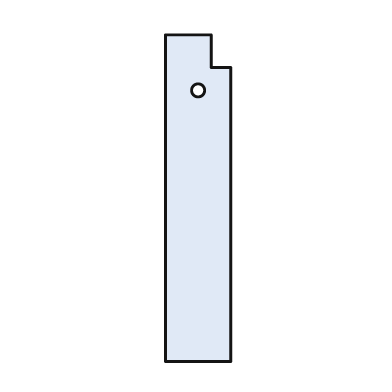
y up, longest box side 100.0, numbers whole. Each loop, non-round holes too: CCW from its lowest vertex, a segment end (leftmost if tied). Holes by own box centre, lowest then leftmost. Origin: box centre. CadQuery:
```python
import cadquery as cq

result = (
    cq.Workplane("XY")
    .moveTo(-10.0, -50.0)
    .lineTo(10.0, -50.0)
    .lineTo(10.0, 40.0)
    .lineTo(4.0, 40.0)
    .lineTo(4.0, 50.0)
    .lineTo(-10.0, 50.0)
    .close()
    .moveTo(0.0, 33.0)
    .circle(2.0)
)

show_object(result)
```